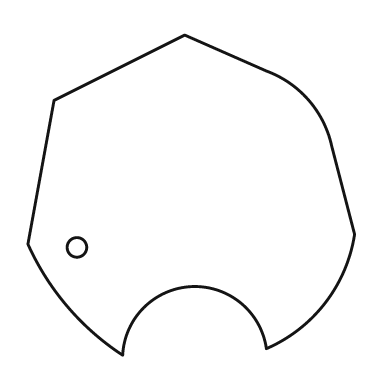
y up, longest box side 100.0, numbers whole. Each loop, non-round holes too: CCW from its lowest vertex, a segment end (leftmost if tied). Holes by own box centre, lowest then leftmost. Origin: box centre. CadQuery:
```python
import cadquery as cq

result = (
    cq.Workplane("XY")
    .moveTo(-21.0, -49.0)
    .threePointArc((0.0, -28.0), (23.0, -47.0))
    .threePointArc((41.0, -33.0), (50.0, -12.0))
    .lineTo(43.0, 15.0)
    .threePointArc((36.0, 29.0), (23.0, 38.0))
    .lineTo(-2.0, 49.0)
    .lineTo(-42.0, 29.0)
    .lineTo(-50.0, -15.0)
    .threePointArc((-38.0, -34.0), (-21.0, -49.0))
    .close()
    .moveTo(-35.0, -16.0)
    .circle(3.0)
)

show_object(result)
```